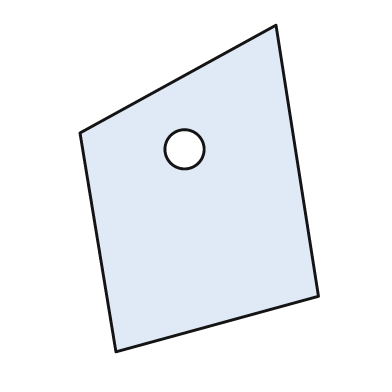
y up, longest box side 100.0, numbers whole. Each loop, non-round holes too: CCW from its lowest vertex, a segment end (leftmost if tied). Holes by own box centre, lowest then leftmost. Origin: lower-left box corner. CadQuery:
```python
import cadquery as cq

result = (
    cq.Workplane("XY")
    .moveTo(11.0, 0.0)
    .lineTo(73.0, 17.0)
    .lineTo(60.0, 100.0)
    .lineTo(0.0, 67.0)
    .close()
    .moveTo(32.0, 62.0)
    .circle(6.0)
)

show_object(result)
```